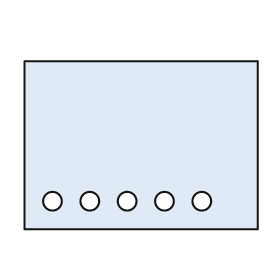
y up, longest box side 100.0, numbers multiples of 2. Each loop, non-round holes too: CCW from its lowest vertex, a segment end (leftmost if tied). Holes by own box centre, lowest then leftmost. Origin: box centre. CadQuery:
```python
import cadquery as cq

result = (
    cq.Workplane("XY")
    .moveTo(-50.0, -36.0)
    .lineTo(50.0, -36.0)
    .lineTo(50.0, 36.0)
    .lineTo(-50.0, 36.0)
    .close()
    .moveTo(-38.0, -24.0)
    .circle(4.0)
    .moveTo(-22.0, -24.0)
    .circle(4.0)
    .moveTo(-6.0, -24.0)
    .circle(4.0)
    .moveTo(10.0, -24.0)
    .circle(4.0)
    .moveTo(26.0, -24.0)
    .circle(4.0)
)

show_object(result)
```